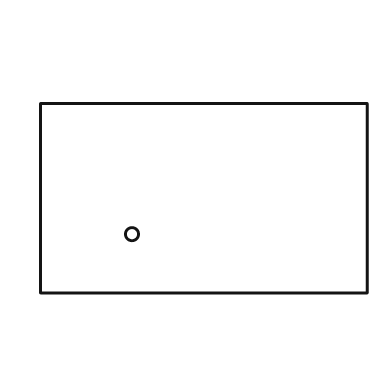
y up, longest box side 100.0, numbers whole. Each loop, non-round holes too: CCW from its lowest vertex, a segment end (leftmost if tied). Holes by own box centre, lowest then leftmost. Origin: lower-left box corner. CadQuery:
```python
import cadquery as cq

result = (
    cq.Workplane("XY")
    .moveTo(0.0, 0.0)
    .lineTo(100.0, 0.0)
    .lineTo(100.0, 58.0)
    .lineTo(0.0, 58.0)
    .close()
    .moveTo(28.0, 18.0)
    .circle(2.0)
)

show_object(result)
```